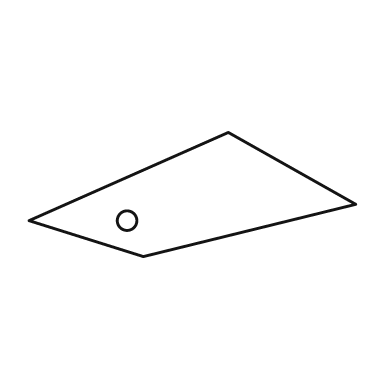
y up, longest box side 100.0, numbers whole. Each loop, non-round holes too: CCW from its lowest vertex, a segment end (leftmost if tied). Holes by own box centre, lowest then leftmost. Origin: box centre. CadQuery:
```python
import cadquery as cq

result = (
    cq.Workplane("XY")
    .moveTo(-15.0, -19.0)
    .lineTo(50.0, -3.0)
    .lineTo(11.0, 19.0)
    .lineTo(-50.0, -8.0)
    .close()
    .moveTo(-20.0, -8.0)
    .circle(3.0)
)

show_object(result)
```